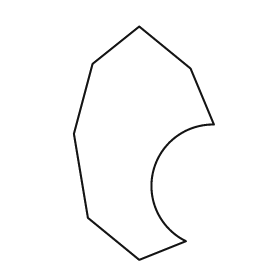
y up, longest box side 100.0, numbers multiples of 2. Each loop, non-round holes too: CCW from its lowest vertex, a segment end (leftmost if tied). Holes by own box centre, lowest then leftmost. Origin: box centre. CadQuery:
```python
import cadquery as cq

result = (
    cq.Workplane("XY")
    .moveTo(-2.0, -50.0)
    .lineTo(18.0, -42.0)
    .threePointArc((4.0, -12.0), (30.0, 8.0))
    .lineTo(20.0, 32.0)
    .lineTo(-2.0, 50.0)
    .lineTo(-22.0, 34.0)
    .lineTo(-30.0, 4.0)
    .lineTo(-24.0, -32.0)
    .close()
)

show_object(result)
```